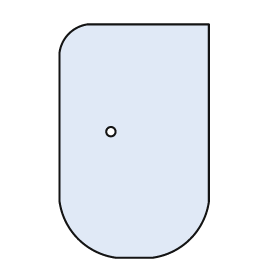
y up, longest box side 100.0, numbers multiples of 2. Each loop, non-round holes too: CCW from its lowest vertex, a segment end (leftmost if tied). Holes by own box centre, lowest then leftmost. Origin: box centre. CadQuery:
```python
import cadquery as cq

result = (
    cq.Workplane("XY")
    .moveTo(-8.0, -50.0)
    .lineTo(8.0, -50.0)
    .threePointArc((24.0, -42.0), (32.0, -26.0))
    .lineTo(32.0, 50.0)
    .lineTo(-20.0, 50.0)
    .threePointArc((-28.0, 46.0), (-32.0, 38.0))
    .lineTo(-32.0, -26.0)
    .threePointArc((-24.0, -42.0), (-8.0, -50.0))
    .close()
    .moveTo(-10.0, 4.0)
    .circle(2.0)
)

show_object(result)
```